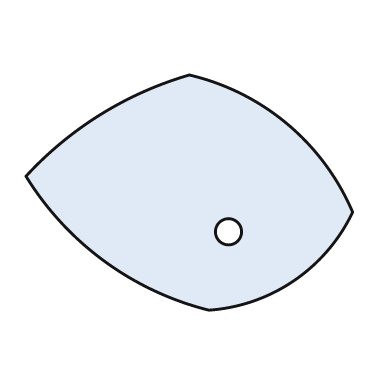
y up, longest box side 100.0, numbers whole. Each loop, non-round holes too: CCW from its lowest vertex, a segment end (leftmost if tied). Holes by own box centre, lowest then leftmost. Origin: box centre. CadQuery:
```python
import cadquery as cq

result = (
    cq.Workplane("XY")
    .moveTo(6.0, -36.0)
    .threePointArc((32.0, -27.0), (50.0, -6.0))
    .threePointArc((30.0, 21.0), (0.0, 36.0))
    .threePointArc((-27.0, 24.0), (-50.0, 5.0))
    .threePointArc((-26.0, -21.0), (6.0, -36.0))
    .close()
    .moveTo(12.0, -12.0)
    .circle(4.0)
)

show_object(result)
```